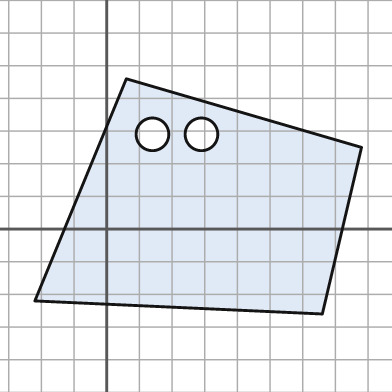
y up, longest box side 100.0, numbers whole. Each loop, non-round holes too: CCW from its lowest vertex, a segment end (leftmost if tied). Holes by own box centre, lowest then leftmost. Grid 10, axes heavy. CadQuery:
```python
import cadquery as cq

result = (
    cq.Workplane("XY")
    .moveTo(66.0, -26.0)
    .lineTo(78.0, 25.0)
    .lineTo(6.0, 46.0)
    .lineTo(-22.0, -22.0)
    .close()
    .moveTo(14.0, 29.0)
    .circle(5.0)
    .moveTo(29.0, 29.0)
    .circle(5.0)
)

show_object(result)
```